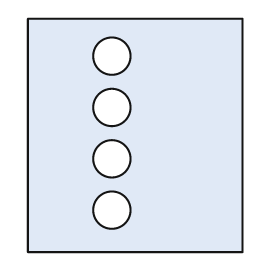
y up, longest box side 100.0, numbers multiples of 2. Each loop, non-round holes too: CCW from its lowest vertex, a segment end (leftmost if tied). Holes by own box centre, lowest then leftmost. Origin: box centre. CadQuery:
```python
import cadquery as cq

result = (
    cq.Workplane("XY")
    .moveTo(-46.0, -50.0)
    .lineTo(46.0, -50.0)
    .lineTo(46.0, 50.0)
    .lineTo(-46.0, 50.0)
    .close()
    .moveTo(-10.0, -32.0)
    .circle(8.0)
    .moveTo(-10.0, -10.0)
    .circle(8.0)
    .moveTo(-10.0, 12.0)
    .circle(8.0)
    .moveTo(-10.0, 34.0)
    .circle(8.0)
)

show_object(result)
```